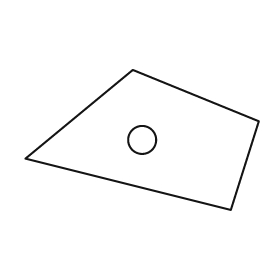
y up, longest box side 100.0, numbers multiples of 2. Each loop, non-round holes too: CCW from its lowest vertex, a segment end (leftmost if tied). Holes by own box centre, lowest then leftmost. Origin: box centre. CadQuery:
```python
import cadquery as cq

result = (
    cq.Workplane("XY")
    .moveTo(38.0, -30.0)
    .lineTo(50.0, 8.0)
    .lineTo(-4.0, 30.0)
    .lineTo(-50.0, -8.0)
    .close()
    .moveTo(0.0, 0.0)
    .circle(6.0)
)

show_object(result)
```